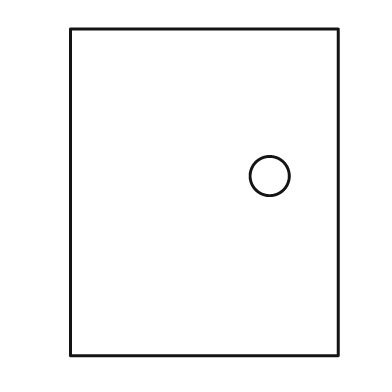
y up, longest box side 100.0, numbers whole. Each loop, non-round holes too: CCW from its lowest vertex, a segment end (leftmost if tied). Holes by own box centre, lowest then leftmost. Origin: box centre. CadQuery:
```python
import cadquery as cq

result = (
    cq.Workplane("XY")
    .moveTo(-41.0, -50.0)
    .lineTo(41.0, -50.0)
    .lineTo(41.0, 50.0)
    .lineTo(-41.0, 50.0)
    .close()
    .moveTo(20.0, 5.0)
    .circle(6.0)
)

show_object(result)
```